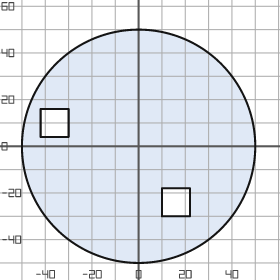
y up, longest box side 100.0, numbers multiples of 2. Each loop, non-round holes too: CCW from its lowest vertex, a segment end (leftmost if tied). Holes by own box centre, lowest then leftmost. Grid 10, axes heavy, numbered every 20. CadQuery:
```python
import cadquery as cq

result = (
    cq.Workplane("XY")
    .moveTo(0.0, 0.0)
    .circle(50.0)
    .moveTo(10.0, -30.0)
    .lineTo(22.0, -30.0)
    .lineTo(22.0, -18.0)
    .lineTo(10.0, -18.0)
    .close()
    .moveTo(-42.0, 4.0)
    .lineTo(-30.0, 4.0)
    .lineTo(-30.0, 16.0)
    .lineTo(-42.0, 16.0)
    .close()
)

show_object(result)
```